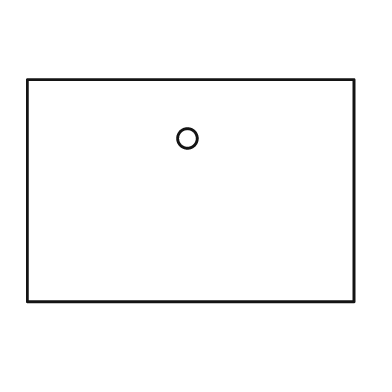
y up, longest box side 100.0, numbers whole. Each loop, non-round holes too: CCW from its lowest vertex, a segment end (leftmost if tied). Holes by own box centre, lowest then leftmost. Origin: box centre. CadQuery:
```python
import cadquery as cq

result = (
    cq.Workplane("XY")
    .moveTo(-50.0, -34.0)
    .lineTo(50.0, -34.0)
    .lineTo(50.0, 34.0)
    .lineTo(-50.0, 34.0)
    .close()
    .moveTo(-1.0, 16.0)
    .circle(3.0)
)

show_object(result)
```